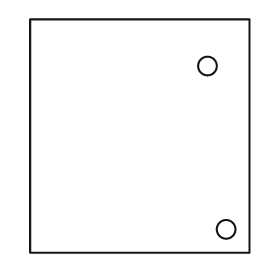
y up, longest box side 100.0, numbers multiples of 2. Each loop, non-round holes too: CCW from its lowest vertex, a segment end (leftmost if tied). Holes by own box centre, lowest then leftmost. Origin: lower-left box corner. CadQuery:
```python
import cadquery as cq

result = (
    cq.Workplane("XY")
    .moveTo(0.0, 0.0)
    .lineTo(94.0, 0.0)
    .lineTo(94.0, 100.0)
    .lineTo(0.0, 100.0)
    .close()
    .moveTo(84.0, 10.0)
    .circle(4.0)
    .moveTo(76.0, 80.0)
    .circle(4.0)
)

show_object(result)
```